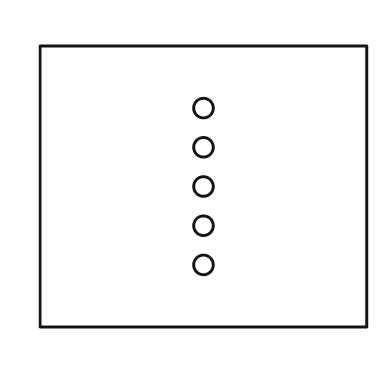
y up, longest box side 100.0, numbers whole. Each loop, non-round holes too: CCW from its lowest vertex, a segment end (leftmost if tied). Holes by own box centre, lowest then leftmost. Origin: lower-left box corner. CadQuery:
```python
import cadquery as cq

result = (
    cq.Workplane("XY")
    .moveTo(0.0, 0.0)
    .lineTo(100.0, 0.0)
    .lineTo(100.0, 86.0)
    .lineTo(0.0, 86.0)
    .close()
    .moveTo(50.0, 19.0)
    .circle(3.0)
    .moveTo(50.0, 31.0)
    .circle(3.0)
    .moveTo(50.0, 43.0)
    .circle(3.0)
    .moveTo(50.0, 55.0)
    .circle(3.0)
    .moveTo(50.0, 67.0)
    .circle(3.0)
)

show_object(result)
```